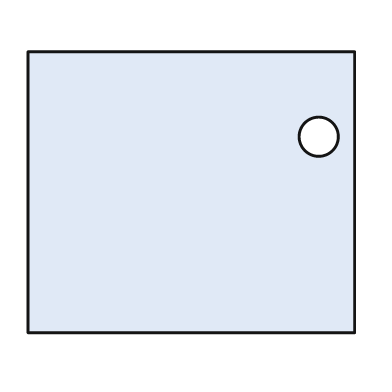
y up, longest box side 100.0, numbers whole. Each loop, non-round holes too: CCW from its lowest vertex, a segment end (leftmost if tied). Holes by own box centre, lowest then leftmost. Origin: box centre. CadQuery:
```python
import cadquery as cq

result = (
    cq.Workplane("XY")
    .moveTo(-50.0, -43.0)
    .lineTo(50.0, -43.0)
    .lineTo(50.0, 43.0)
    .lineTo(-50.0, 43.0)
    .close()
    .moveTo(39.0, 17.0)
    .circle(6.0)
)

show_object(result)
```